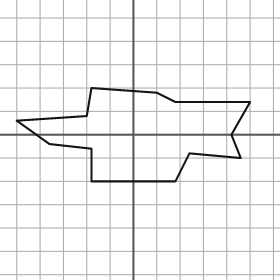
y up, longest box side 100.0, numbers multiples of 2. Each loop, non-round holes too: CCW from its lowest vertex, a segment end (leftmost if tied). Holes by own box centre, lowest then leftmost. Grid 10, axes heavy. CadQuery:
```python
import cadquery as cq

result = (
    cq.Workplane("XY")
    .moveTo(-18.0, -20.0)
    .lineTo(18.0, -20.0)
    .lineTo(24.0, -8.0)
    .lineTo(46.0, -10.0)
    .lineTo(42.0, 0.0)
    .lineTo(50.0, 14.0)
    .lineTo(18.0, 14.0)
    .lineTo(10.0, 18.0)
    .lineTo(-18.0, 20.0)
    .lineTo(-20.0, 8.0)
    .lineTo(-50.0, 6.0)
    .lineTo(-36.0, -4.0)
    .lineTo(-18.0, -6.0)
    .close()
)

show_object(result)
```